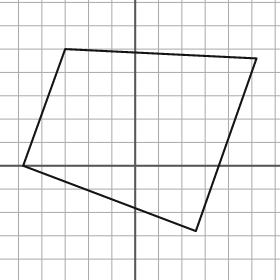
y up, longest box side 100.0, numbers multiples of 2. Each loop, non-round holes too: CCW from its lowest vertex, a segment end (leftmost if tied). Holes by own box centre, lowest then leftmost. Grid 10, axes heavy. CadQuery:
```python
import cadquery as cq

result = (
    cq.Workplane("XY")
    .moveTo(26.0, -28.0)
    .lineTo(52.0, 46.0)
    .lineTo(-30.0, 50.0)
    .lineTo(-48.0, 0.0)
    .close()
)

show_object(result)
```